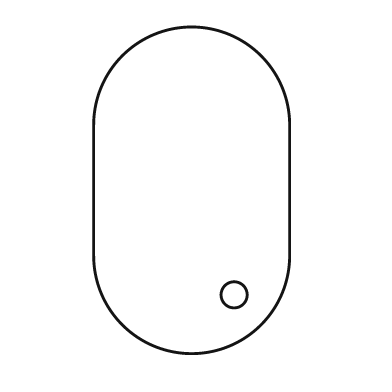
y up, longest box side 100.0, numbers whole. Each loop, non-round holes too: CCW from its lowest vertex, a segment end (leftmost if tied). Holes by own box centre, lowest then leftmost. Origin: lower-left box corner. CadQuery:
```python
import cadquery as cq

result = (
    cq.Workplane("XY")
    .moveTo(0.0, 30.0)
    .threePointArc((30.0, 0.0), (60.0, 30.0))
    .lineTo(60.0, 70.0)
    .threePointArc((30.0, 100.0), (0.0, 70.0))
    .close()
    .moveTo(43.0, 18.0)
    .circle(4.0)
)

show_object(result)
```